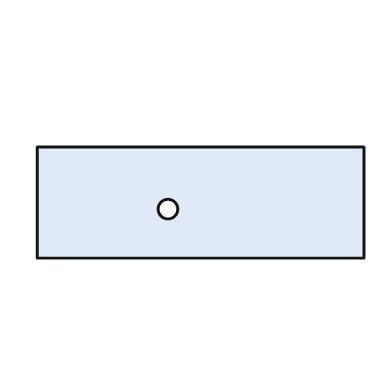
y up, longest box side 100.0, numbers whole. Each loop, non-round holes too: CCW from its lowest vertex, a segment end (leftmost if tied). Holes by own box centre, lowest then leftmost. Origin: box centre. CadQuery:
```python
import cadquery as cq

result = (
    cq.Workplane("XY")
    .moveTo(-50.0, -17.0)
    .lineTo(50.0, -17.0)
    .lineTo(50.0, 17.0)
    .lineTo(-50.0, 17.0)
    .close()
    .moveTo(-10.0, -2.0)
    .circle(3.0)
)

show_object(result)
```